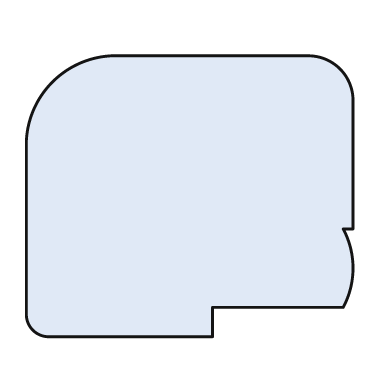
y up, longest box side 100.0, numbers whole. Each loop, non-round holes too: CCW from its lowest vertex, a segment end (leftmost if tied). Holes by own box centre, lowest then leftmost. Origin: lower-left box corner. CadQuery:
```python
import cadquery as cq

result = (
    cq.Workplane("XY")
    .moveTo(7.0, 0.0)
    .lineTo(57.0, 0.0)
    .lineTo(57.0, 9.0)
    .lineTo(97.0, 9.0)
    .threePointArc((100.0, 21.0), (97.0, 33.0))
    .lineTo(100.0, 33.0)
    .lineTo(100.0, 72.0)
    .threePointArc((96.0, 82.0), (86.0, 86.0))
    .lineTo(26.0, 86.0)
    .threePointArc((8.0, 78.0), (0.0, 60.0))
    .lineTo(0.0, 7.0)
    .threePointArc((2.0, 2.0), (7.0, 0.0))
    .close()
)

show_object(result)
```